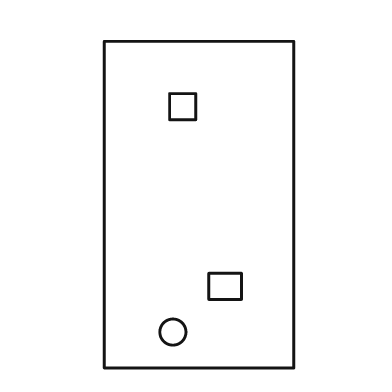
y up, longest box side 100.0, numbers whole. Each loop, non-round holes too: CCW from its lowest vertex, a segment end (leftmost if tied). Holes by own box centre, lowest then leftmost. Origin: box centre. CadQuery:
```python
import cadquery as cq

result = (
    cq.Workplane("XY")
    .moveTo(-29.0, -50.0)
    .lineTo(29.0, -50.0)
    .lineTo(29.0, 50.0)
    .lineTo(-29.0, 50.0)
    .close()
    .moveTo(-8.0, -39.0)
    .circle(4.0)
    .moveTo(3.0, -29.0)
    .lineTo(13.0, -29.0)
    .lineTo(13.0, -21.0)
    .lineTo(3.0, -21.0)
    .close()
    .moveTo(-9.0, 26.0)
    .lineTo(-1.0, 26.0)
    .lineTo(-1.0, 34.0)
    .lineTo(-9.0, 34.0)
    .close()
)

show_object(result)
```